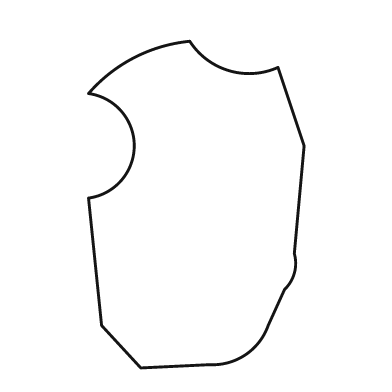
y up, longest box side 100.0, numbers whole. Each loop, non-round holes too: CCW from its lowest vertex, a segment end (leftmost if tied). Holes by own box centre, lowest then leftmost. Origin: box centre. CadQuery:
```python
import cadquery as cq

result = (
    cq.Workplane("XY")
    .moveTo(-17.0, -50.0)
    .lineTo(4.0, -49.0)
    .threePointArc((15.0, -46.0), (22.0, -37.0))
    .lineTo(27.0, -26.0)
    .threePointArc((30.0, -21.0), (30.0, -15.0))
    .lineTo(33.0, 18.0)
    .lineTo(25.0, 42.0)
    .threePointArc((10.0, 41.0), (-2.0, 50.0))
    .threePointArc((-19.0, 45.0), (-33.0, 34.0))
    .threePointArc((-19.0, 18.0), (-33.0, 2.0))
    .lineTo(-29.0, -37.0)
    .close()
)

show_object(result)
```